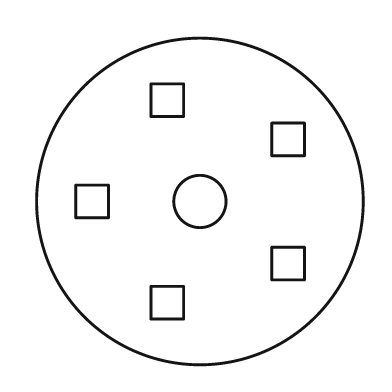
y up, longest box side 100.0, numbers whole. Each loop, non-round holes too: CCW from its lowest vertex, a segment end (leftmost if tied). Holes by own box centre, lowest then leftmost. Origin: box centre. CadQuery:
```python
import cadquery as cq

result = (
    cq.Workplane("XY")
    .moveTo(0.0, 0.0)
    .circle(50.0)
    .moveTo(-15.0, -36.0)
    .lineTo(-5.0, -36.0)
    .lineTo(-5.0, -26.0)
    .lineTo(-15.0, -26.0)
    .close()
    .moveTo(22.0, -24.0)
    .lineTo(32.0, -24.0)
    .lineTo(32.0, -14.0)
    .lineTo(22.0, -14.0)
    .close()
    .moveTo(-38.0, -5.0)
    .lineTo(-28.0, -5.0)
    .lineTo(-28.0, 5.0)
    .lineTo(-38.0, 5.0)
    .close()
    .moveTo(0.0, 0.0)
    .circle(8.0)
    .moveTo(22.0, 14.0)
    .lineTo(32.0, 14.0)
    .lineTo(32.0, 24.0)
    .lineTo(22.0, 24.0)
    .close()
    .moveTo(-15.0, 26.0)
    .lineTo(-5.0, 26.0)
    .lineTo(-5.0, 36.0)
    .lineTo(-15.0, 36.0)
    .close()
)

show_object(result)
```